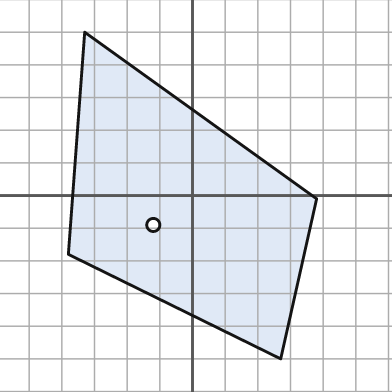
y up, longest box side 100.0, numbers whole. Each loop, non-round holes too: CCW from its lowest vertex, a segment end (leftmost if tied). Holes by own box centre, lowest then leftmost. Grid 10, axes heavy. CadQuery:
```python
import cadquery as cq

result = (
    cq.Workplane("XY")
    .moveTo(27.0, -50.0)
    .lineTo(38.0, -1.0)
    .lineTo(-33.0, 50.0)
    .lineTo(-38.0, -18.0)
    .close()
    .moveTo(-12.0, -9.0)
    .circle(2.0)
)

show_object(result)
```